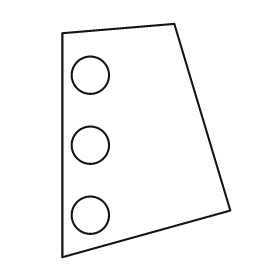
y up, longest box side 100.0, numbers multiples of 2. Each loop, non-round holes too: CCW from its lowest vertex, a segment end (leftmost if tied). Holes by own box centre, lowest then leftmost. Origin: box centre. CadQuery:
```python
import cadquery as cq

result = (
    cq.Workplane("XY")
    .moveTo(-36.0, -50.0)
    .lineTo(36.0, -30.0)
    .lineTo(12.0, 50.0)
    .lineTo(-36.0, 46.0)
    .close()
    .moveTo(-24.0, -32.0)
    .circle(8.0)
    .moveTo(-24.0, -2.0)
    .circle(8.0)
    .moveTo(-24.0, 28.0)
    .circle(8.0)
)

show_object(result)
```